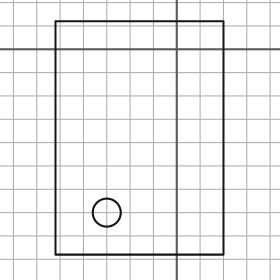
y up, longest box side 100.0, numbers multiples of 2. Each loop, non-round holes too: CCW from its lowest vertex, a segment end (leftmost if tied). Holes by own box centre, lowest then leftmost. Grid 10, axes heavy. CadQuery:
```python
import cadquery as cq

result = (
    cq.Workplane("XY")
    .moveTo(-52.0, -88.0)
    .lineTo(20.0, -88.0)
    .lineTo(20.0, 12.0)
    .lineTo(-52.0, 12.0)
    .close()
    .moveTo(-30.0, -70.0)
    .circle(6.0)
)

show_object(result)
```